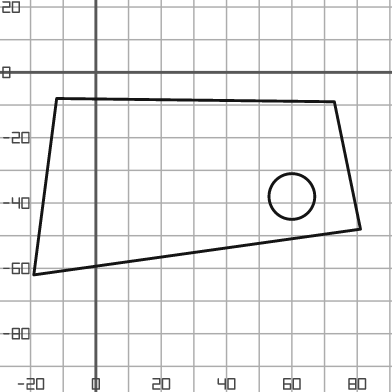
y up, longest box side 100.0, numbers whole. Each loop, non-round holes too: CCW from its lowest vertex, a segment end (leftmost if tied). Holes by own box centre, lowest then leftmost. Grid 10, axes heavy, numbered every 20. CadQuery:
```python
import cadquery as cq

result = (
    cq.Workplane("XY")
    .moveTo(-19.0, -62.0)
    .lineTo(81.0, -48.0)
    .lineTo(73.0, -9.0)
    .lineTo(-12.0, -8.0)
    .close()
    .moveTo(60.0, -38.0)
    .circle(7.0)
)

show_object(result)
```